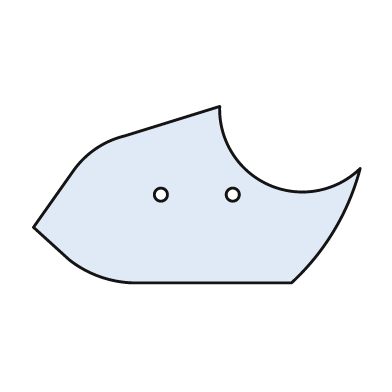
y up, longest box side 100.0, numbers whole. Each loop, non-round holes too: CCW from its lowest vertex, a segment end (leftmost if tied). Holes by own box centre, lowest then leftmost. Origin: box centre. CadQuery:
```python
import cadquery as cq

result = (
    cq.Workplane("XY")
    .moveTo(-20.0, -27.0)
    .lineTo(29.0, -27.0)
    .threePointArc((42.0, -11.0), (50.0, 8.0))
    .threePointArc((22.0, 3.0), (7.0, 27.0))
    .lineTo(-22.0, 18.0)
    .threePointArc((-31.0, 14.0), (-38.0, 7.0))
    .lineTo(-50.0, -10.0)
    .lineTo(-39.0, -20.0)
    .threePointArc((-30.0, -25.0), (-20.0, -27.0))
    .close()
    .moveTo(-11.0, 0.0)
    .circle(2.0)
    .moveTo(11.0, 0.0)
    .circle(2.0)
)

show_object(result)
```